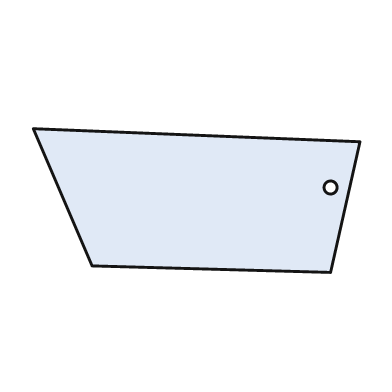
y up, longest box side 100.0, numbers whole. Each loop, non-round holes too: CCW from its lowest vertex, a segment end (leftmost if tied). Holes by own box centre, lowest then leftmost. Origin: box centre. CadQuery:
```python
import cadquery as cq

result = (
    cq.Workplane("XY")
    .moveTo(41.0, -22.0)
    .lineTo(50.0, 18.0)
    .lineTo(-50.0, 22.0)
    .lineTo(-32.0, -20.0)
    .close()
    .moveTo(41.0, 4.0)
    .circle(2.0)
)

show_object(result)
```